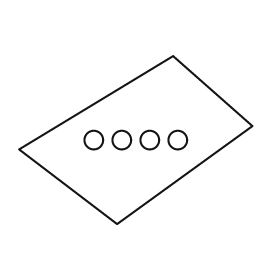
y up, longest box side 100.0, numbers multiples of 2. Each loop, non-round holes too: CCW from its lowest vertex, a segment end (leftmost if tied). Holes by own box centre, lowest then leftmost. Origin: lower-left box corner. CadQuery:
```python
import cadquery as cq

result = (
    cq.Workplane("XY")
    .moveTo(42.0, 0.0)
    .lineTo(100.0, 42.0)
    .lineTo(66.0, 72.0)
    .lineTo(0.0, 32.0)
    .close()
    .moveTo(32.0, 36.0)
    .circle(4.0)
    .moveTo(44.0, 36.0)
    .circle(4.0)
    .moveTo(56.0, 36.0)
    .circle(4.0)
    .moveTo(68.0, 36.0)
    .circle(4.0)
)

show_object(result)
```